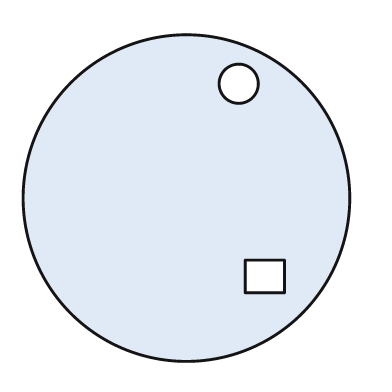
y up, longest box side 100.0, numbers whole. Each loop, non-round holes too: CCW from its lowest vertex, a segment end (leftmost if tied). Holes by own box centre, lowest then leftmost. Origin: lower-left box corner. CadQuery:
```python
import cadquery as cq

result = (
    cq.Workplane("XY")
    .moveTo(50.0, 50.0)
    .circle(50.0)
    .moveTo(68.0, 21.0)
    .lineTo(80.0, 21.0)
    .lineTo(80.0, 31.0)
    .lineTo(68.0, 31.0)
    .close()
    .moveTo(66.0, 85.0)
    .circle(6.0)
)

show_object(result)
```